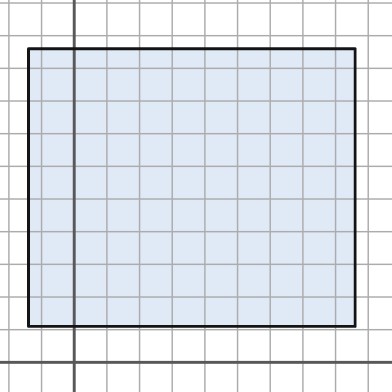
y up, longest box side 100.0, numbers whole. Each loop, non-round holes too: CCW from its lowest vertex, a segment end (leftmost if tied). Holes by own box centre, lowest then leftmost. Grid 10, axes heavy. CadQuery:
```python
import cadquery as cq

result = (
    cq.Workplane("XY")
    .moveTo(-14.0, 11.0)
    .lineTo(86.0, 11.0)
    .lineTo(86.0, 96.0)
    .lineTo(-14.0, 96.0)
    .close()
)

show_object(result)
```